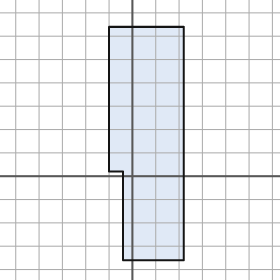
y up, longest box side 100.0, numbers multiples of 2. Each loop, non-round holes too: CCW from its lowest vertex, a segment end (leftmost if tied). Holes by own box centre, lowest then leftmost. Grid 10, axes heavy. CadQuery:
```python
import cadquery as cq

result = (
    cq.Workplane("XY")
    .moveTo(-4.0, -36.0)
    .lineTo(22.0, -36.0)
    .lineTo(22.0, 64.0)
    .lineTo(-10.0, 64.0)
    .lineTo(-10.0, 2.0)
    .lineTo(-4.0, 2.0)
    .close()
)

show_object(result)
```